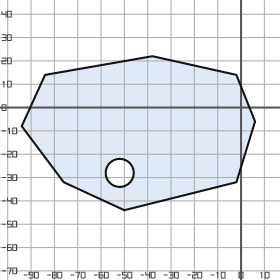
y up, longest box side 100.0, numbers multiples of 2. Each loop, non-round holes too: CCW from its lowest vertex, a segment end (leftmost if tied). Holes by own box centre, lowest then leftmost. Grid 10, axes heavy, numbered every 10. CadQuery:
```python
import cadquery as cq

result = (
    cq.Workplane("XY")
    .moveTo(-50.0, -44.0)
    .lineTo(-2.0, -32.0)
    .lineTo(6.0, -6.0)
    .lineTo(-2.0, 14.0)
    .lineTo(-38.0, 22.0)
    .lineTo(-84.0, 14.0)
    .lineTo(-94.0, -8.0)
    .lineTo(-76.0, -32.0)
    .close()
    .moveTo(-52.0, -28.0)
    .circle(6.0)
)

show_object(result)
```